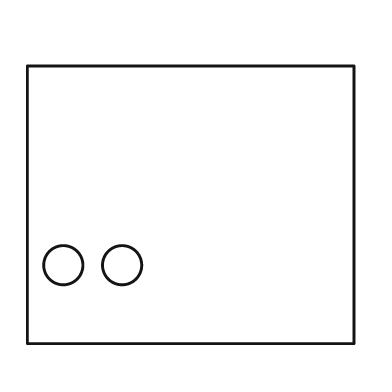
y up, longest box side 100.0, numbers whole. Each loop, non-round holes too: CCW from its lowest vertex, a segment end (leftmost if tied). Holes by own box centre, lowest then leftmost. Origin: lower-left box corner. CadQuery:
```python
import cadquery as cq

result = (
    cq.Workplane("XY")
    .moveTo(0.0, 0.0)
    .lineTo(100.0, 0.0)
    .lineTo(100.0, 85.0)
    .lineTo(0.0, 85.0)
    .close()
    .moveTo(11.0, 24.0)
    .circle(6.0)
    .moveTo(29.0, 24.0)
    .circle(6.0)
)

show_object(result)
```